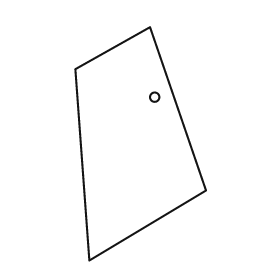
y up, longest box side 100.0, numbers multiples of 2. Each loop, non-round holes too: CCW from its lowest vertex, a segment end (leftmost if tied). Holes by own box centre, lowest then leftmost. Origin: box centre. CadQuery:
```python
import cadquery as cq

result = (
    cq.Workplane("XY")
    .moveTo(-22.0, -50.0)
    .lineTo(28.0, -20.0)
    .lineTo(4.0, 50.0)
    .lineTo(-28.0, 32.0)
    .close()
    .moveTo(6.0, 20.0)
    .circle(2.0)
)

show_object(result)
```